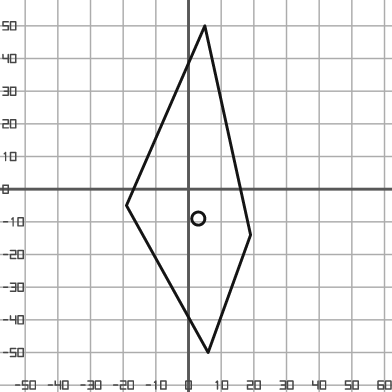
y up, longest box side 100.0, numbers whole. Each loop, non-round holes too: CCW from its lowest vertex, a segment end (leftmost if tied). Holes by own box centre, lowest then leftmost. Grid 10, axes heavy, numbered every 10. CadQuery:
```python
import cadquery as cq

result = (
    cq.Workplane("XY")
    .moveTo(6.0, -50.0)
    .lineTo(19.0, -14.0)
    .lineTo(5.0, 50.0)
    .lineTo(-19.0, -5.0)
    .close()
    .moveTo(3.0, -9.0)
    .circle(2.0)
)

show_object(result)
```